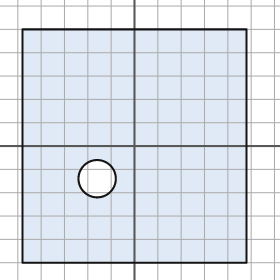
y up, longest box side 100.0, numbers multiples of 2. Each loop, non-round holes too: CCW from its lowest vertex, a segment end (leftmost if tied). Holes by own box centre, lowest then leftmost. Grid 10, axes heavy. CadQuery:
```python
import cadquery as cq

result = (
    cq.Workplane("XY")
    .moveTo(-48.0, -50.0)
    .lineTo(48.0, -50.0)
    .lineTo(48.0, 50.0)
    .lineTo(-48.0, 50.0)
    .close()
    .moveTo(-16.0, -14.0)
    .circle(8.0)
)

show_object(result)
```